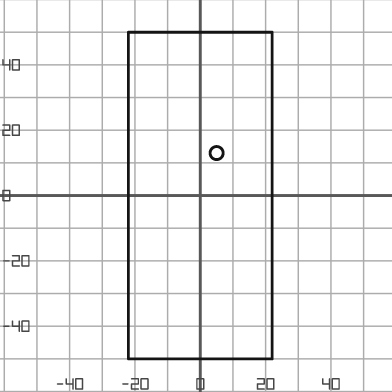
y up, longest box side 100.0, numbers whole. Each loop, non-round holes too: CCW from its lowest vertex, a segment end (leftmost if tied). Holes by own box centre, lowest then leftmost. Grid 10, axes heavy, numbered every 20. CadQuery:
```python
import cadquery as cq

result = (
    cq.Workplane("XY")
    .moveTo(-22.0, -50.0)
    .lineTo(22.0, -50.0)
    .lineTo(22.0, 50.0)
    .lineTo(-22.0, 50.0)
    .close()
    .moveTo(5.0, 13.0)
    .circle(2.0)
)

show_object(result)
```